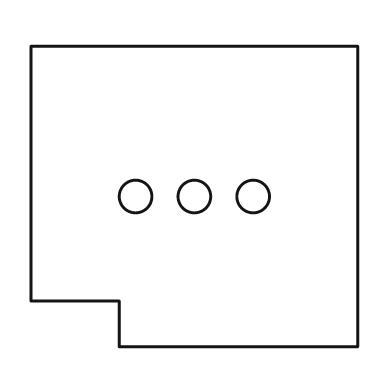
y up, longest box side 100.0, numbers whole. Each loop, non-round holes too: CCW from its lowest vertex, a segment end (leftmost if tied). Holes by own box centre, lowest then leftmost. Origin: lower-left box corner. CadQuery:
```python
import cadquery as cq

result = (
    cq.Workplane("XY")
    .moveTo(27.0, 0.0)
    .lineTo(100.0, 0.0)
    .lineTo(100.0, 92.0)
    .lineTo(0.0, 92.0)
    .lineTo(0.0, 14.0)
    .lineTo(27.0, 14.0)
    .close()
    .moveTo(32.0, 46.0)
    .circle(5.0)
    .moveTo(50.0, 46.0)
    .circle(5.0)
    .moveTo(68.0, 46.0)
    .circle(5.0)
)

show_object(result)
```